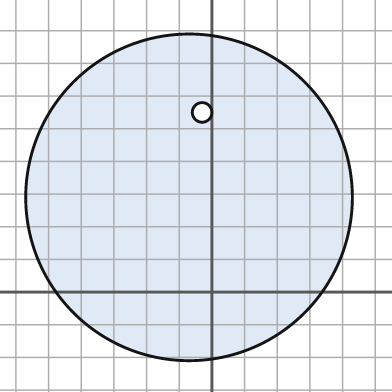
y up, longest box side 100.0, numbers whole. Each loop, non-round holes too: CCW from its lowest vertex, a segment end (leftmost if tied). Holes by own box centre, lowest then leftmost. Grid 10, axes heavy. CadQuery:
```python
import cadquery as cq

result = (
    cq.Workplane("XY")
    .moveTo(-7.0, 29.0)
    .circle(50.0)
    .moveTo(-3.0, 55.0)
    .circle(3.0)
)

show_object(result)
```